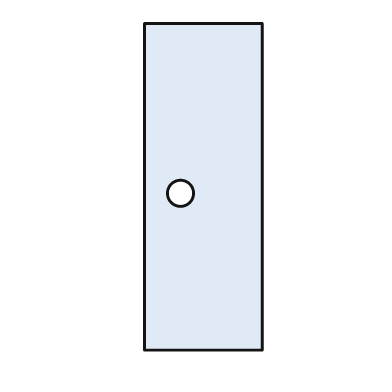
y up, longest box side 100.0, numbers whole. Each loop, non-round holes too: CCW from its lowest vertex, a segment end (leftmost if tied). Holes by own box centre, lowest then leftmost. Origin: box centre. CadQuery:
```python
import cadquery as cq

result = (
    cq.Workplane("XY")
    .moveTo(-18.0, -50.0)
    .lineTo(18.0, -50.0)
    .lineTo(18.0, 50.0)
    .lineTo(-18.0, 50.0)
    .close()
    .moveTo(-7.0, -2.0)
    .circle(4.0)
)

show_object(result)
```